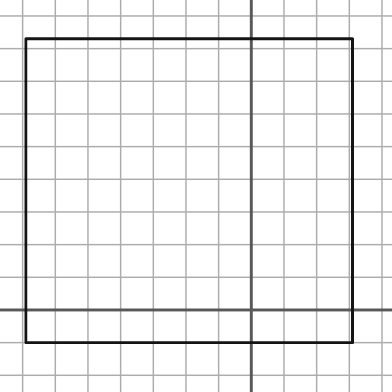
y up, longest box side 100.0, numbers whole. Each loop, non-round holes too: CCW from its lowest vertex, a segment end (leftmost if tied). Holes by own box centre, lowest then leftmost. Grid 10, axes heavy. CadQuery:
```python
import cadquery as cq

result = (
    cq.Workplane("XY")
    .moveTo(-69.0, -10.0)
    .lineTo(31.0, -10.0)
    .lineTo(31.0, 83.0)
    .lineTo(-69.0, 83.0)
    .close()
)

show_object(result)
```